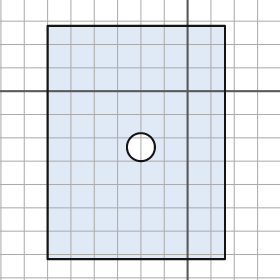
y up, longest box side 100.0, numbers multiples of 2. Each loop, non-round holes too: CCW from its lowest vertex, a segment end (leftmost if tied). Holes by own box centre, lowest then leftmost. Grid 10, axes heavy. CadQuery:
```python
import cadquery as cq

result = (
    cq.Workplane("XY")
    .moveTo(-60.0, -72.0)
    .lineTo(16.0, -72.0)
    .lineTo(16.0, 28.0)
    .lineTo(-60.0, 28.0)
    .close()
    .moveTo(-20.0, -24.0)
    .circle(6.0)
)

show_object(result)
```